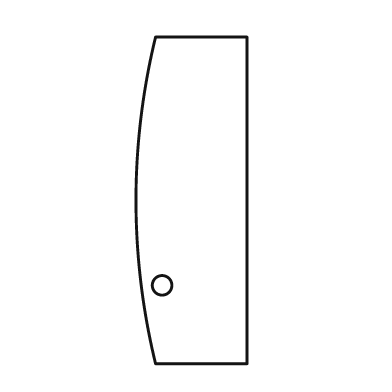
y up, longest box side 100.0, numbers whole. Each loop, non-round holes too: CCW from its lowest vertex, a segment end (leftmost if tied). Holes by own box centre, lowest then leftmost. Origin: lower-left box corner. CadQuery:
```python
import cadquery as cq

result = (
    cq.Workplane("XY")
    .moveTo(6.0, 0.0)
    .lineTo(34.0, 0.0)
    .lineTo(34.0, 100.0)
    .lineTo(6.0, 100.0)
    .threePointArc((0.0, 50.0), (6.0, 0.0))
    .close()
    .moveTo(8.0, 24.0)
    .circle(3.0)
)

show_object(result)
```